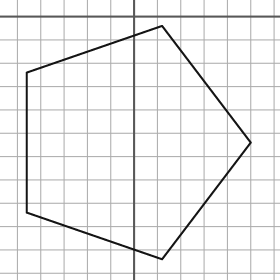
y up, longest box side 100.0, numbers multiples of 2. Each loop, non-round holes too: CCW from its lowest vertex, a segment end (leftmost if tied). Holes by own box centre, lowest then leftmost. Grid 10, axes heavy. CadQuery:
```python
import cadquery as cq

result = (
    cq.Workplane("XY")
    .moveTo(12.0, -104.0)
    .lineTo(50.0, -54.0)
    .lineTo(12.0, -4.0)
    .lineTo(-46.0, -24.0)
    .lineTo(-46.0, -84.0)
    .close()
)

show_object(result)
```